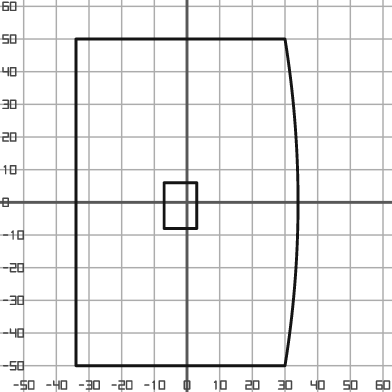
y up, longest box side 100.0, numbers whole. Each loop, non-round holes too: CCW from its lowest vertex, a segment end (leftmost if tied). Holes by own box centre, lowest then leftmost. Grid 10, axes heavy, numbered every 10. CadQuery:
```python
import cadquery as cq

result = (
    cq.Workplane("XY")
    .moveTo(-34.0, -50.0)
    .lineTo(30.0, -50.0)
    .threePointArc((34.0, 0.0), (30.0, 50.0))
    .lineTo(-34.0, 50.0)
    .close()
    .moveTo(-7.0, -8.0)
    .lineTo(3.0, -8.0)
    .lineTo(3.0, 6.0)
    .lineTo(-7.0, 6.0)
    .close()
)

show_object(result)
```